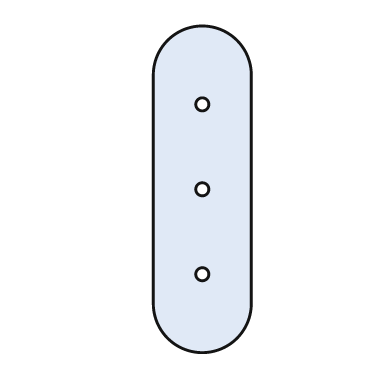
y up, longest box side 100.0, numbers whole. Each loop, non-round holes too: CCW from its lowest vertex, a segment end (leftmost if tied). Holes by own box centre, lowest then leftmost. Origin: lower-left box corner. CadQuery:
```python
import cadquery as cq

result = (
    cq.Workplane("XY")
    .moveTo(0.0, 15.0)
    .threePointArc((15.0, 0.0), (30.0, 15.0))
    .lineTo(30.0, 85.0)
    .threePointArc((15.0, 100.0), (0.0, 85.0))
    .close()
    .moveTo(15.0, 24.0)
    .circle(2.0)
    .moveTo(15.0, 50.0)
    .circle(2.0)
    .moveTo(15.0, 76.0)
    .circle(2.0)
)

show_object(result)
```